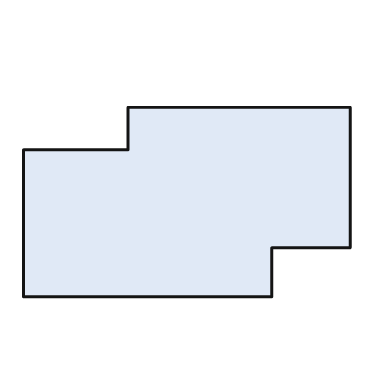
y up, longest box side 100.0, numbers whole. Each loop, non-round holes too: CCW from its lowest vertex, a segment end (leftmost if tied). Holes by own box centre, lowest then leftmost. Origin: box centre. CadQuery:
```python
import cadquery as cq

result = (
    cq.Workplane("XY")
    .moveTo(-50.0, -29.0)
    .lineTo(26.0, -29.0)
    .lineTo(26.0, -14.0)
    .lineTo(50.0, -14.0)
    .lineTo(50.0, 29.0)
    .lineTo(-18.0, 29.0)
    .lineTo(-18.0, 16.0)
    .lineTo(-50.0, 16.0)
    .close()
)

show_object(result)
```